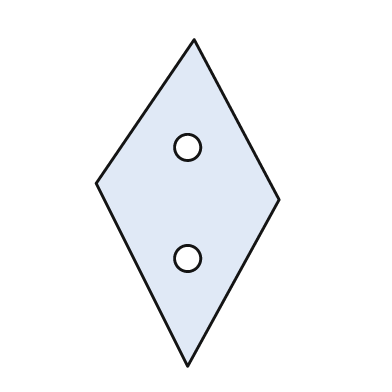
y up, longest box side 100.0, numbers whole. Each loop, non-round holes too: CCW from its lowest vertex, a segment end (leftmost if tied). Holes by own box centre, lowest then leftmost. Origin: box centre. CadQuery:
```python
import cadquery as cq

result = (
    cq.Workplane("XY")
    .moveTo(0.0, -50.0)
    .lineTo(28.0, 1.0)
    .lineTo(2.0, 50.0)
    .lineTo(-28.0, 6.0)
    .close()
    .moveTo(0.0, -17.0)
    .circle(4.0)
    .moveTo(0.0, 17.0)
    .circle(4.0)
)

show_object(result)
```